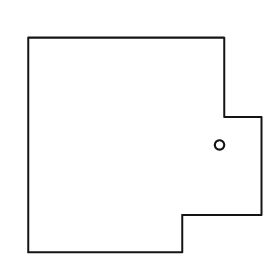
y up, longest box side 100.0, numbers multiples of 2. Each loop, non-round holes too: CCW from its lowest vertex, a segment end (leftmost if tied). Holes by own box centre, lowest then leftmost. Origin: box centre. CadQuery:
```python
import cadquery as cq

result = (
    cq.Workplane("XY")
    .moveTo(-50.0, -46.0)
    .lineTo(16.0, -46.0)
    .lineTo(16.0, -30.0)
    .lineTo(50.0, -30.0)
    .lineTo(50.0, 12.0)
    .lineTo(34.0, 12.0)
    .lineTo(34.0, 46.0)
    .lineTo(-50.0, 46.0)
    .close()
    .moveTo(32.0, 0.0)
    .circle(2.0)
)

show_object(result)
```